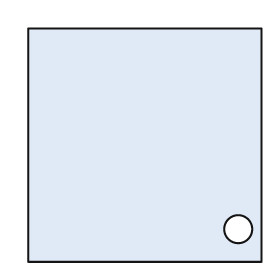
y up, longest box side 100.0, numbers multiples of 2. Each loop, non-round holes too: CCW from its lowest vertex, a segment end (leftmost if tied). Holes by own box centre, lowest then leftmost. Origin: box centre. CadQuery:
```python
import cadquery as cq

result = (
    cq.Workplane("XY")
    .moveTo(-50.0, -50.0)
    .lineTo(50.0, -50.0)
    .lineTo(50.0, 50.0)
    .lineTo(-50.0, 50.0)
    .close()
    .moveTo(40.0, -36.0)
    .circle(6.0)
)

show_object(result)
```